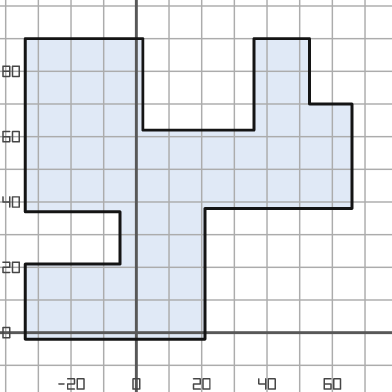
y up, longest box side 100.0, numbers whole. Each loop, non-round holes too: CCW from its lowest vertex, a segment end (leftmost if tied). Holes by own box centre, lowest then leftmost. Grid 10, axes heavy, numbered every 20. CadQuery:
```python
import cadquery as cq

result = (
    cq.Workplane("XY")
    .moveTo(-34.0, -2.0)
    .lineTo(21.0, -2.0)
    .lineTo(21.0, 38.0)
    .lineTo(66.0, 38.0)
    .lineTo(66.0, 70.0)
    .lineTo(53.0, 70.0)
    .lineTo(53.0, 90.0)
    .lineTo(36.0, 90.0)
    .lineTo(36.0, 62.0)
    .lineTo(2.0, 62.0)
    .lineTo(2.0, 90.0)
    .lineTo(-34.0, 90.0)
    .lineTo(-34.0, 37.0)
    .lineTo(-5.0, 37.0)
    .lineTo(-5.0, 21.0)
    .lineTo(-34.0, 21.0)
    .close()
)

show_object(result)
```